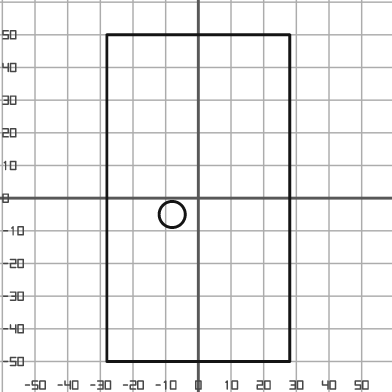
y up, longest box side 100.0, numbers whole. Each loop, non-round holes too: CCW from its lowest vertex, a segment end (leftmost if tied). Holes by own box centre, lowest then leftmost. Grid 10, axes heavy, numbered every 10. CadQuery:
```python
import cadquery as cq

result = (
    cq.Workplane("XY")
    .moveTo(-28.0, -50.0)
    .lineTo(28.0, -50.0)
    .lineTo(28.0, 50.0)
    .lineTo(-28.0, 50.0)
    .close()
    .moveTo(-8.0, -5.0)
    .circle(4.0)
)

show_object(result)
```